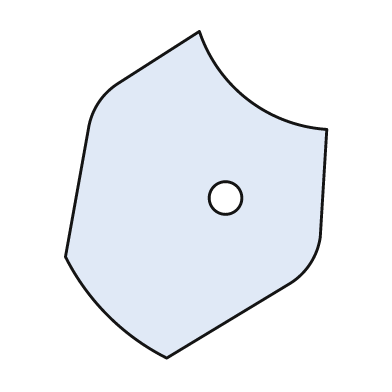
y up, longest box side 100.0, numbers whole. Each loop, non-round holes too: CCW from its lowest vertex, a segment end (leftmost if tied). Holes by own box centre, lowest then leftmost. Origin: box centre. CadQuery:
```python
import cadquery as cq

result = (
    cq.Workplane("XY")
    .moveTo(-9.0, -50.0)
    .lineTo(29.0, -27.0)
    .threePointArc((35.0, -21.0), (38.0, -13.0))
    .lineTo(40.0, 20.0)
    .threePointArc((16.0, 29.0), (1.0, 50.0))
    .lineTo(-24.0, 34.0)
    .threePointArc((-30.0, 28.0), (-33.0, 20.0))
    .lineTo(-40.0, -19.0)
    .threePointArc((-27.0, -37.0), (-9.0, -50.0))
    .close()
    .moveTo(9.0, -1.0)
    .circle(5.0)
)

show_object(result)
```